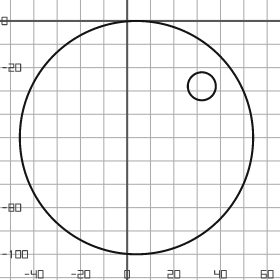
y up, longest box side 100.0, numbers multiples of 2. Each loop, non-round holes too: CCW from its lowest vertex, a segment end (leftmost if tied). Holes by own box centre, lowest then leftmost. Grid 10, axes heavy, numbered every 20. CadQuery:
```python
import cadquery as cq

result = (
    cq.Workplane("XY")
    .moveTo(4.0, -50.0)
    .circle(50.0)
    .moveTo(32.0, -28.0)
    .circle(6.0)
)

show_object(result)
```